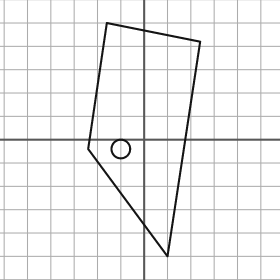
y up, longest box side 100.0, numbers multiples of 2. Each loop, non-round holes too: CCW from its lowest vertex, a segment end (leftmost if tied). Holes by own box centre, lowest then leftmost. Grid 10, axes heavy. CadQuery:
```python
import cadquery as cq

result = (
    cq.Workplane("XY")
    .moveTo(10.0, -50.0)
    .lineTo(24.0, 42.0)
    .lineTo(-16.0, 50.0)
    .lineTo(-24.0, -4.0)
    .close()
    .moveTo(-10.0, -4.0)
    .circle(4.0)
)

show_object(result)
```